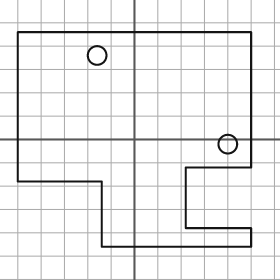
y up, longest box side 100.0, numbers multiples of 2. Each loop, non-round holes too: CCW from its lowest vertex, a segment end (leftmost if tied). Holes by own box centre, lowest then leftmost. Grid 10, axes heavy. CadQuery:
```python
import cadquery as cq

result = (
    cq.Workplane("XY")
    .moveTo(-14.0, -46.0)
    .lineTo(50.0, -46.0)
    .lineTo(50.0, -38.0)
    .lineTo(22.0, -38.0)
    .lineTo(22.0, -12.0)
    .lineTo(50.0, -12.0)
    .lineTo(50.0, 46.0)
    .lineTo(-50.0, 46.0)
    .lineTo(-50.0, -18.0)
    .lineTo(-14.0, -18.0)
    .close()
    .moveTo(40.0, -2.0)
    .circle(4.0)
    .moveTo(-16.0, 36.0)
    .circle(4.0)
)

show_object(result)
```